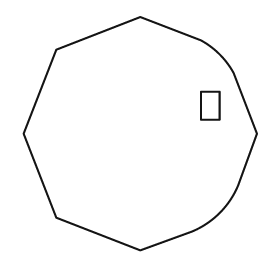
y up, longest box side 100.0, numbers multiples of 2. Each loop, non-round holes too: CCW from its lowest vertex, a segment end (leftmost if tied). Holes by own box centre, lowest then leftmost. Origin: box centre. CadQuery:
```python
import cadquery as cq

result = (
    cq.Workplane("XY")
    .moveTo(0.0, -50.0)
    .lineTo(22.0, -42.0)
    .threePointArc((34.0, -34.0), (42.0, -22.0))
    .lineTo(50.0, 0.0)
    .lineTo(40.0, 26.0)
    .threePointArc((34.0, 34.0), (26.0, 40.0))
    .lineTo(0.0, 50.0)
    .lineTo(-36.0, 36.0)
    .lineTo(-50.0, 0.0)
    .lineTo(-36.0, -36.0)
    .close()
    .moveTo(26.0, 6.0)
    .lineTo(34.0, 6.0)
    .lineTo(34.0, 18.0)
    .lineTo(26.0, 18.0)
    .close()
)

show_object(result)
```